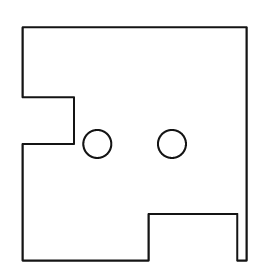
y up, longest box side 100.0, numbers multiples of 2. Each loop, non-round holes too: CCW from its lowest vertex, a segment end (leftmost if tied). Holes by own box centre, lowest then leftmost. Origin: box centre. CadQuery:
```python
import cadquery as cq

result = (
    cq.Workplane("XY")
    .moveTo(-48.0, -50.0)
    .lineTo(6.0, -50.0)
    .lineTo(6.0, -30.0)
    .lineTo(44.0, -30.0)
    .lineTo(44.0, -50.0)
    .lineTo(48.0, -50.0)
    .lineTo(48.0, 50.0)
    .lineTo(-48.0, 50.0)
    .lineTo(-48.0, 20.0)
    .lineTo(-26.0, 20.0)
    .lineTo(-26.0, 0.0)
    .lineTo(-48.0, 0.0)
    .close()
    .moveTo(-16.0, 0.0)
    .circle(6.0)
    .moveTo(16.0, 0.0)
    .circle(6.0)
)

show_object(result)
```